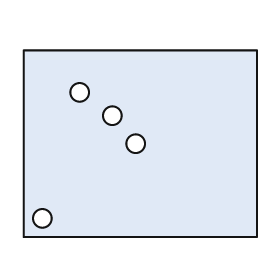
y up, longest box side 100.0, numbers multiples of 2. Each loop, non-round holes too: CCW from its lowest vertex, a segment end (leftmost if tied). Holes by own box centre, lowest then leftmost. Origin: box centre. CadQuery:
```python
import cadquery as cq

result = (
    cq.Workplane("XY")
    .moveTo(-50.0, -40.0)
    .lineTo(50.0, -40.0)
    .lineTo(50.0, 40.0)
    .lineTo(-50.0, 40.0)
    .close()
    .moveTo(-42.0, -32.0)
    .circle(4.0)
    .moveTo(-2.0, 0.0)
    .circle(4.0)
    .moveTo(-12.0, 12.0)
    .circle(4.0)
    .moveTo(-26.0, 22.0)
    .circle(4.0)
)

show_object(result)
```